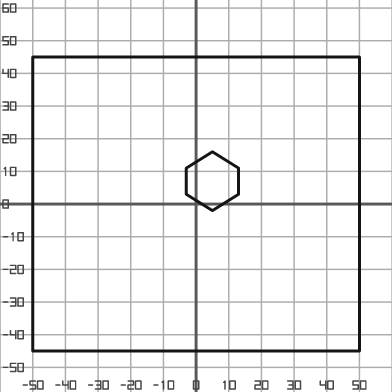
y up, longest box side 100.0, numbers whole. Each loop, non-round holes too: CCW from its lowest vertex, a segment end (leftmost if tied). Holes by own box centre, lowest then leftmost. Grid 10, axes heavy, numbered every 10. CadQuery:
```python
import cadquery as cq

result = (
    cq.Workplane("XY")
    .moveTo(-50.0, -45.0)
    .lineTo(50.0, -45.0)
    .lineTo(50.0, 45.0)
    .lineTo(-50.0, 45.0)
    .close()
    .moveTo(5.0, -2.0)
    .lineTo(13.0, 3.0)
    .lineTo(13.0, 11.0)
    .lineTo(5.0, 16.0)
    .lineTo(-3.0, 11.0)
    .lineTo(-3.0, 3.0)
    .close()
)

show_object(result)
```